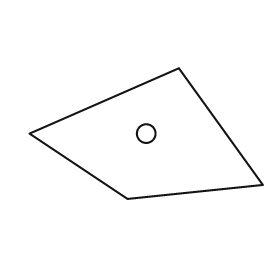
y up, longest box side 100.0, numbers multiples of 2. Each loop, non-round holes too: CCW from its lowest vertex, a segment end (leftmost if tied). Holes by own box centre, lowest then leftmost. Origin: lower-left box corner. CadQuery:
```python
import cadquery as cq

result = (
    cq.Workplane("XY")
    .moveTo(42.0, 0.0)
    .lineTo(100.0, 6.0)
    .lineTo(64.0, 56.0)
    .lineTo(0.0, 28.0)
    .close()
    .moveTo(50.0, 28.0)
    .circle(4.0)
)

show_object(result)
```